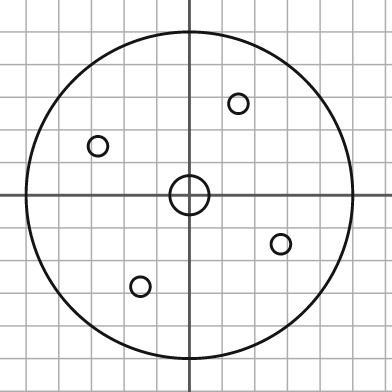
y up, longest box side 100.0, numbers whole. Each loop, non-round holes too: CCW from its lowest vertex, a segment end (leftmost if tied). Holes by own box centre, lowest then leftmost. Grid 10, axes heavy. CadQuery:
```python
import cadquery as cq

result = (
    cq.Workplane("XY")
    .moveTo(0.0, 0.0)
    .circle(50.0)
    .moveTo(-15.0, -28.0)
    .circle(3.0)
    .moveTo(28.0, -15.0)
    .circle(3.0)
    .moveTo(0.0, 0.0)
    .circle(6.0)
    .moveTo(-28.0, 15.0)
    .circle(3.0)
    .moveTo(15.0, 28.0)
    .circle(3.0)
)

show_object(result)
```